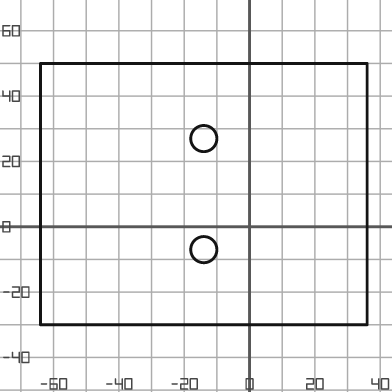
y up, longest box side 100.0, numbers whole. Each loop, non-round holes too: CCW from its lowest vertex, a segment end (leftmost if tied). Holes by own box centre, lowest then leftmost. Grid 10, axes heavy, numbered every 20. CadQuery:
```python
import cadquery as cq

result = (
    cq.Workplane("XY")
    .moveTo(-64.0, -30.0)
    .lineTo(36.0, -30.0)
    .lineTo(36.0, 50.0)
    .lineTo(-64.0, 50.0)
    .close()
    .moveTo(-14.0, -7.0)
    .circle(4.0)
    .moveTo(-14.0, 27.0)
    .circle(4.0)
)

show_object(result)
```